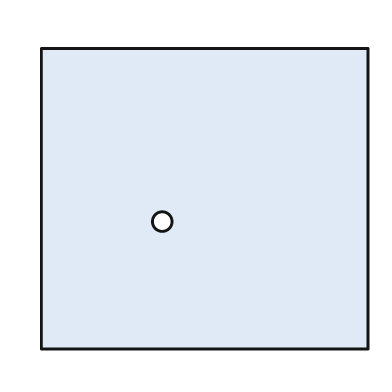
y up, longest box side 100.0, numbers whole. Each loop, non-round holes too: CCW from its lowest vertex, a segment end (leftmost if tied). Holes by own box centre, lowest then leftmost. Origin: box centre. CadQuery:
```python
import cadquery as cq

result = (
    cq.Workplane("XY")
    .moveTo(-50.0, -46.0)
    .lineTo(50.0, -46.0)
    .lineTo(50.0, 46.0)
    .lineTo(-50.0, 46.0)
    .close()
    .moveTo(-13.0, -7.0)
    .circle(3.0)
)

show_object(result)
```